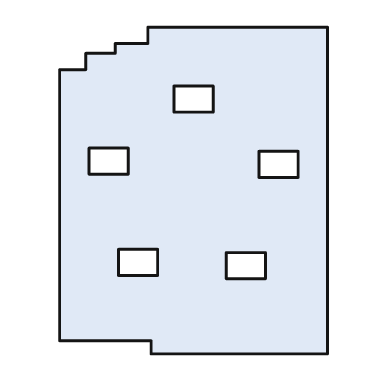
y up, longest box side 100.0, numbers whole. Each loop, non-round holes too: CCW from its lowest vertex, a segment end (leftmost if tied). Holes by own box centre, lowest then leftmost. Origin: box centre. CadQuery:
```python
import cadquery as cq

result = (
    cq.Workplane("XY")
    .moveTo(-13.0, -50.0)
    .lineTo(41.0, -50.0)
    .lineTo(41.0, 50.0)
    .lineTo(-14.0, 50.0)
    .lineTo(-14.0, 45.0)
    .lineTo(-24.0, 45.0)
    .lineTo(-24.0, 42.0)
    .lineTo(-33.0, 42.0)
    .lineTo(-33.0, 37.0)
    .lineTo(-41.0, 37.0)
    .lineTo(-41.0, -46.0)
    .lineTo(-13.0, -46.0)
    .close()
    .moveTo(10.0, -27.0)
    .lineTo(22.0, -27.0)
    .lineTo(22.0, -19.0)
    .lineTo(10.0, -19.0)
    .close()
    .moveTo(-23.0, -26.0)
    .lineTo(-11.0, -26.0)
    .lineTo(-11.0, -18.0)
    .lineTo(-23.0, -18.0)
    .close()
    .moveTo(20.0, 4.0)
    .lineTo(32.0, 4.0)
    .lineTo(32.0, 12.0)
    .lineTo(20.0, 12.0)
    .close()
    .moveTo(-32.0, 5.0)
    .lineTo(-20.0, 5.0)
    .lineTo(-20.0, 13.0)
    .lineTo(-32.0, 13.0)
    .close()
    .moveTo(-6.0, 24.0)
    .lineTo(6.0, 24.0)
    .lineTo(6.0, 32.0)
    .lineTo(-6.0, 32.0)
    .close()
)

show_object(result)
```